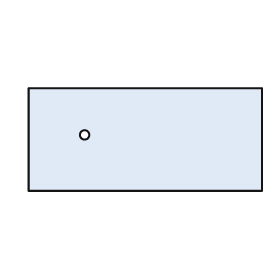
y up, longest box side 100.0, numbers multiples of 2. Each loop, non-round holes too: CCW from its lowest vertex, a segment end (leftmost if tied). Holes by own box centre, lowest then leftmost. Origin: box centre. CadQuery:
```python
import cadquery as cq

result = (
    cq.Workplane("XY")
    .moveTo(-50.0, -22.0)
    .lineTo(50.0, -22.0)
    .lineTo(50.0, 22.0)
    .lineTo(-50.0, 22.0)
    .close()
    .moveTo(-26.0, 2.0)
    .circle(2.0)
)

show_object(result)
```